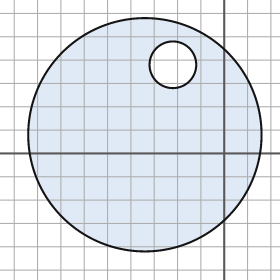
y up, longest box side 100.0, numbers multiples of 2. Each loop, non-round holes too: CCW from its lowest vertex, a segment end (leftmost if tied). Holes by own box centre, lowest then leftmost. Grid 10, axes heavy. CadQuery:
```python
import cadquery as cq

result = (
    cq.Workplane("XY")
    .moveTo(-34.0, 8.0)
    .circle(50.0)
    .moveTo(-22.0, 38.0)
    .circle(10.0)
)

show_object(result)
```